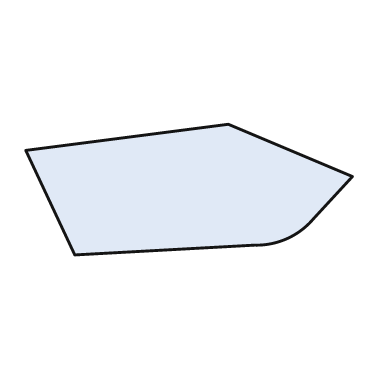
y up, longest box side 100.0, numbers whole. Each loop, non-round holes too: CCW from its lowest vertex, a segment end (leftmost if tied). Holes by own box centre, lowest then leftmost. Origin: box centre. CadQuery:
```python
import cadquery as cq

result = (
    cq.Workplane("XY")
    .moveTo(-35.0, -20.0)
    .lineTo(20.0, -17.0)
    .threePointArc((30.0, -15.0), (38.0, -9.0))
    .lineTo(50.0, 4.0)
    .lineTo(12.0, 20.0)
    .lineTo(-50.0, 12.0)
    .close()
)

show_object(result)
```